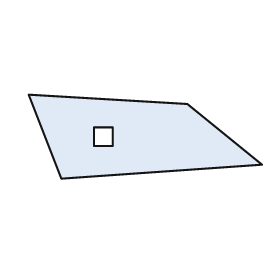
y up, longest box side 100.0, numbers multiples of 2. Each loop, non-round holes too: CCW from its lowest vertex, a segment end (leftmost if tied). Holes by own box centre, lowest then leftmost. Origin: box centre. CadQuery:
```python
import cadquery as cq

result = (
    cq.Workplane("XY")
    .moveTo(-36.0, -18.0)
    .lineTo(50.0, -12.0)
    .lineTo(18.0, 14.0)
    .lineTo(-50.0, 18.0)
    .close()
    .moveTo(-22.0, -4.0)
    .lineTo(-14.0, -4.0)
    .lineTo(-14.0, 4.0)
    .lineTo(-22.0, 4.0)
    .close()
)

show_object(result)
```